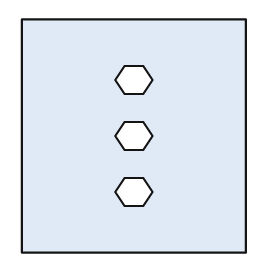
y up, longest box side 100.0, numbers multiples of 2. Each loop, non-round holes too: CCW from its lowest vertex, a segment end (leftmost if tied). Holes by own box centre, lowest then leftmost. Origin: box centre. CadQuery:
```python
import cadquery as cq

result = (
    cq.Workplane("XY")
    .moveTo(-48.0, -50.0)
    .lineTo(48.0, -50.0)
    .lineTo(48.0, 50.0)
    .lineTo(-48.0, 50.0)
    .close()
    .moveTo(-4.0, -30.0)
    .lineTo(4.0, -30.0)
    .lineTo(8.0, -24.0)
    .lineTo(4.0, -18.0)
    .lineTo(-4.0, -18.0)
    .lineTo(-8.0, -24.0)
    .close()
    .moveTo(-4.0, -6.0)
    .lineTo(4.0, -6.0)
    .lineTo(8.0, 0.0)
    .lineTo(4.0, 6.0)
    .lineTo(-4.0, 6.0)
    .lineTo(-8.0, 0.0)
    .close()
    .moveTo(-4.0, 18.0)
    .lineTo(4.0, 18.0)
    .lineTo(8.0, 24.0)
    .lineTo(4.0, 30.0)
    .lineTo(-4.0, 30.0)
    .lineTo(-8.0, 24.0)
    .close()
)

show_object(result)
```